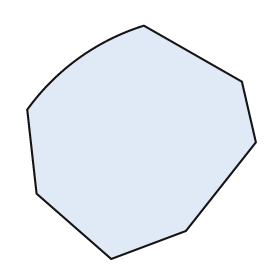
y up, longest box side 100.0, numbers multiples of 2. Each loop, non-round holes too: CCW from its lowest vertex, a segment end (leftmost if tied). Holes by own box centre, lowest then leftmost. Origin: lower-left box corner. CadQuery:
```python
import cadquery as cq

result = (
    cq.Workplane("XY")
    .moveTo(36.0, 0.0)
    .lineTo(68.0, 12.0)
    .lineTo(98.0, 50.0)
    .lineTo(92.0, 76.0)
    .lineTo(50.0, 100.0)
    .threePointArc((22.0, 86.0), (0.0, 64.0))
    .lineTo(4.0, 28.0)
    .close()
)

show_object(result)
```